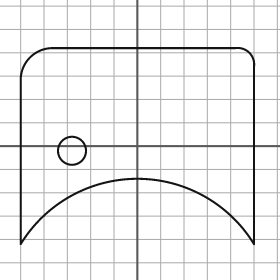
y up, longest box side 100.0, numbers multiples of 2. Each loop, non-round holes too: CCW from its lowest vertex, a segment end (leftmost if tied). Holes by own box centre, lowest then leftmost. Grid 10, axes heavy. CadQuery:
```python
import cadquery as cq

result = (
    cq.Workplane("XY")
    .moveTo(-50.0, -42.0)
    .threePointArc((0.0, -14.0), (50.0, -42.0))
    .lineTo(50.0, 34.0)
    .threePointArc((48.0, 40.0), (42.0, 42.0))
    .lineTo(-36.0, 42.0)
    .threePointArc((-46.0, 38.0), (-50.0, 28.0))
    .close()
    .moveTo(-28.0, -2.0)
    .circle(6.0)
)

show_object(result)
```